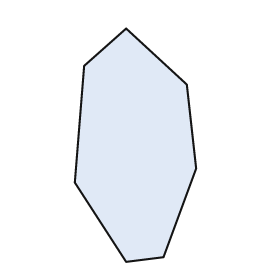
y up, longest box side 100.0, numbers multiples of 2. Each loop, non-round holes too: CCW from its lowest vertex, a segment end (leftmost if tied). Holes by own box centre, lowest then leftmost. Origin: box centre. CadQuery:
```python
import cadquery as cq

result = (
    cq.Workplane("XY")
    .moveTo(-4.0, -50.0)
    .lineTo(12.0, -48.0)
    .lineTo(26.0, -10.0)
    .lineTo(22.0, 26.0)
    .lineTo(-4.0, 50.0)
    .lineTo(-22.0, 34.0)
    .lineTo(-26.0, -16.0)
    .close()
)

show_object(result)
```